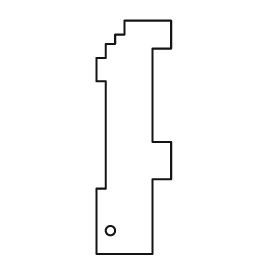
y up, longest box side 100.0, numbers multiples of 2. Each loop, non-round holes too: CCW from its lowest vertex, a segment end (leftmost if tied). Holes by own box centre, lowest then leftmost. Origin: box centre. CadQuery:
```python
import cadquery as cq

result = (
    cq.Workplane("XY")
    .moveTo(-16.0, -50.0)
    .lineTo(8.0, -50.0)
    .lineTo(8.0, -18.0)
    .lineTo(16.0, -18.0)
    .lineTo(16.0, -2.0)
    .lineTo(8.0, -2.0)
    .lineTo(8.0, 38.0)
    .lineTo(16.0, 38.0)
    .lineTo(16.0, 50.0)
    .lineTo(-4.0, 50.0)
    .lineTo(-4.0, 44.0)
    .lineTo(-8.0, 44.0)
    .lineTo(-8.0, 40.0)
    .lineTo(-12.0, 40.0)
    .lineTo(-12.0, 34.0)
    .lineTo(-16.0, 34.0)
    .lineTo(-16.0, 24.0)
    .lineTo(-12.0, 24.0)
    .lineTo(-12.0, -22.0)
    .lineTo(-16.0, -22.0)
    .close()
    .moveTo(-10.0, -40.0)
    .circle(2.0)
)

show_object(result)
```